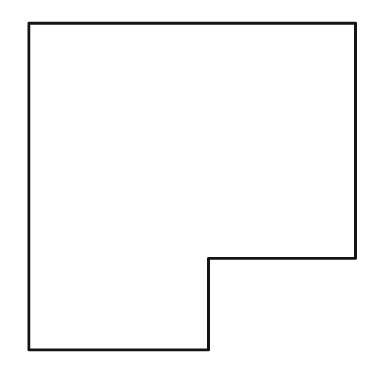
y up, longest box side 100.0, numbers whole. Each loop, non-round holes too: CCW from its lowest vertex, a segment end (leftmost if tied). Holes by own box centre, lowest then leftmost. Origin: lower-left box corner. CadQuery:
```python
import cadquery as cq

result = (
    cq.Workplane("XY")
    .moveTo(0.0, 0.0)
    .lineTo(55.0, 0.0)
    .lineTo(55.0, 28.0)
    .lineTo(100.0, 28.0)
    .lineTo(100.0, 100.0)
    .lineTo(0.0, 100.0)
    .close()
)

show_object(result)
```